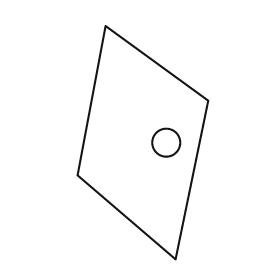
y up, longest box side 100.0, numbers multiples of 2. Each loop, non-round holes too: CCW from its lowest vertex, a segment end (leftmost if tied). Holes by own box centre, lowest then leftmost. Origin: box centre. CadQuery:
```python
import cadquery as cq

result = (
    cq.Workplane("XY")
    .moveTo(14.0, -50.0)
    .lineTo(28.0, 18.0)
    .lineTo(-16.0, 50.0)
    .lineTo(-28.0, -14.0)
    .close()
    .moveTo(10.0, 0.0)
    .circle(6.0)
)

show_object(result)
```